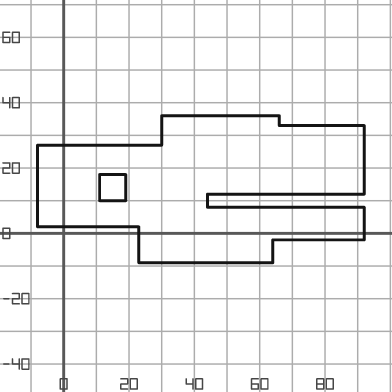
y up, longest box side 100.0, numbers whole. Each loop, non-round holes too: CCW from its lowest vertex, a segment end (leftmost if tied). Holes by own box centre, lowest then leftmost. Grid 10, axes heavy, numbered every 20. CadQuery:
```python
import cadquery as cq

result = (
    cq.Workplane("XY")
    .moveTo(23.0, -9.0)
    .lineTo(64.0, -9.0)
    .lineTo(64.0, -2.0)
    .lineTo(92.0, -2.0)
    .lineTo(92.0, 8.0)
    .lineTo(44.0, 8.0)
    .lineTo(44.0, 12.0)
    .lineTo(92.0, 12.0)
    .lineTo(92.0, 33.0)
    .lineTo(66.0, 33.0)
    .lineTo(66.0, 36.0)
    .lineTo(30.0, 36.0)
    .lineTo(30.0, 27.0)
    .lineTo(-8.0, 27.0)
    .lineTo(-8.0, 2.0)
    .lineTo(23.0, 2.0)
    .close()
    .moveTo(11.0, 10.0)
    .lineTo(19.0, 10.0)
    .lineTo(19.0, 18.0)
    .lineTo(11.0, 18.0)
    .close()
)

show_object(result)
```